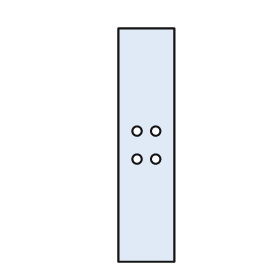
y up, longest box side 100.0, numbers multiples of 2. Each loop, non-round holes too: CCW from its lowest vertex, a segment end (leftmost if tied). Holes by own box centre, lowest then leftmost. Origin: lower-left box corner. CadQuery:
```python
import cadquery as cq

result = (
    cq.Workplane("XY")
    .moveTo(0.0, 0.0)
    .lineTo(24.0, 0.0)
    .lineTo(24.0, 100.0)
    .lineTo(0.0, 100.0)
    .close()
    .moveTo(8.0, 44.0)
    .circle(2.0)
    .moveTo(16.0, 44.0)
    .circle(2.0)
    .moveTo(8.0, 56.0)
    .circle(2.0)
    .moveTo(16.0, 56.0)
    .circle(2.0)
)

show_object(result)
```